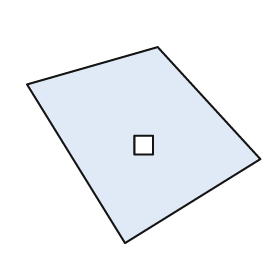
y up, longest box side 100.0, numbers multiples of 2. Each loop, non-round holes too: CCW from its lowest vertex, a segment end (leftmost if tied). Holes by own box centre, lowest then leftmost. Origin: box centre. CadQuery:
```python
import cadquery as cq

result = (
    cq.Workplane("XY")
    .moveTo(-8.0, -42.0)
    .lineTo(50.0, -6.0)
    .lineTo(6.0, 42.0)
    .lineTo(-50.0, 26.0)
    .close()
    .moveTo(-4.0, -4.0)
    .lineTo(4.0, -4.0)
    .lineTo(4.0, 4.0)
    .lineTo(-4.0, 4.0)
    .close()
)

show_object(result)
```